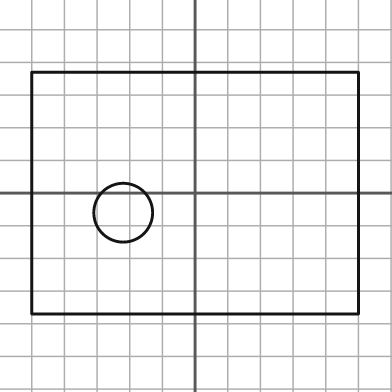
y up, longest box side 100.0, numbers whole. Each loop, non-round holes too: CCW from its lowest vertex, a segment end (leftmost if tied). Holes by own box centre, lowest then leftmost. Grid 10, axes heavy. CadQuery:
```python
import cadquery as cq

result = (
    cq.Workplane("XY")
    .moveTo(-50.0, -37.0)
    .lineTo(50.0, -37.0)
    .lineTo(50.0, 37.0)
    .lineTo(-50.0, 37.0)
    .close()
    .moveTo(-22.0, -6.0)
    .circle(9.0)
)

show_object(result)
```